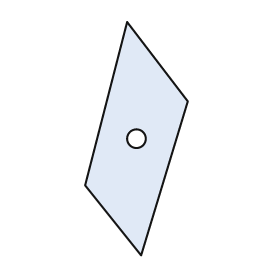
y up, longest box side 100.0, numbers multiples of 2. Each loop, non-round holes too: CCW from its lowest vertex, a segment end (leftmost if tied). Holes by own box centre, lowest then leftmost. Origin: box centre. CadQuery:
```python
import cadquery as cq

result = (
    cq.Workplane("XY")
    .moveTo(2.0, -50.0)
    .lineTo(22.0, 16.0)
    .lineTo(-4.0, 50.0)
    .lineTo(-22.0, -20.0)
    .close()
    .moveTo(0.0, 0.0)
    .circle(4.0)
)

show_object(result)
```